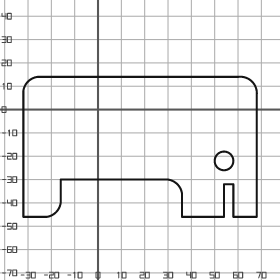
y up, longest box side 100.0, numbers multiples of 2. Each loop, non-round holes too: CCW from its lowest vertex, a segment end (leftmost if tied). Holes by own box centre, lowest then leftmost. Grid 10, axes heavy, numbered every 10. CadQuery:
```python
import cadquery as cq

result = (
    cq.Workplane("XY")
    .moveTo(-32.0, -46.0)
    .lineTo(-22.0, -46.0)
    .threePointArc((-18.0, -44.0), (-16.0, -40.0))
    .lineTo(-16.0, -30.0)
    .lineTo(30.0, -30.0)
    .threePointArc((34.0, -32.0), (36.0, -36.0))
    .lineTo(36.0, -46.0)
    .lineTo(54.0, -46.0)
    .lineTo(54.0, -32.0)
    .lineTo(58.0, -32.0)
    .lineTo(58.0, -46.0)
    .lineTo(68.0, -46.0)
    .lineTo(68.0, 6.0)
    .threePointArc((66.0, 12.0), (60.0, 14.0))
    .lineTo(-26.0, 14.0)
    .threePointArc((-30.0, 12.0), (-32.0, 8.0))
    .close()
    .moveTo(54.0, -22.0)
    .circle(4.0)
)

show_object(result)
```